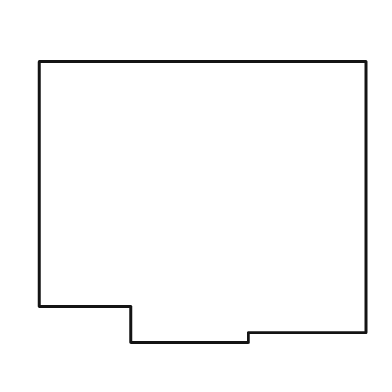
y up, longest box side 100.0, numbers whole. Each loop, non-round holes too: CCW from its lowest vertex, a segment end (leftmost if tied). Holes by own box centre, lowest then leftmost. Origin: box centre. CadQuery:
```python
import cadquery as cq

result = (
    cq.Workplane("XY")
    .moveTo(-22.0, -43.0)
    .lineTo(14.0, -43.0)
    .lineTo(14.0, -40.0)
    .lineTo(50.0, -40.0)
    .lineTo(50.0, 43.0)
    .lineTo(-50.0, 43.0)
    .lineTo(-50.0, -32.0)
    .lineTo(-22.0, -32.0)
    .close()
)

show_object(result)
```